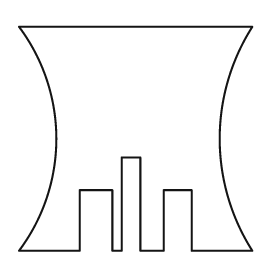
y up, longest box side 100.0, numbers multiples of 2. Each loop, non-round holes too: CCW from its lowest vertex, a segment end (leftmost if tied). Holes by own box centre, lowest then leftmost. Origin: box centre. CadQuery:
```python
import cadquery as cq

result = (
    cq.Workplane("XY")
    .moveTo(-50.0, -48.0)
    .lineTo(-24.0, -48.0)
    .lineTo(-24.0, -22.0)
    .lineTo(-10.0, -22.0)
    .lineTo(-10.0, -48.0)
    .lineTo(-6.0, -48.0)
    .lineTo(-6.0, -8.0)
    .lineTo(2.0, -8.0)
    .lineTo(2.0, -48.0)
    .lineTo(12.0, -48.0)
    .lineTo(12.0, -22.0)
    .lineTo(24.0, -22.0)
    .lineTo(24.0, -48.0)
    .lineTo(50.0, -48.0)
    .threePointArc((36.0, 0.0), (50.0, 48.0))
    .lineTo(-50.0, 48.0)
    .threePointArc((-34.0, 0.0), (-50.0, -48.0))
    .close()
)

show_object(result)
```